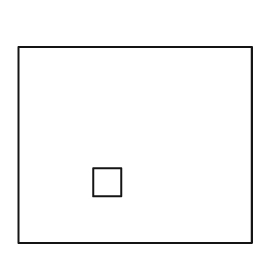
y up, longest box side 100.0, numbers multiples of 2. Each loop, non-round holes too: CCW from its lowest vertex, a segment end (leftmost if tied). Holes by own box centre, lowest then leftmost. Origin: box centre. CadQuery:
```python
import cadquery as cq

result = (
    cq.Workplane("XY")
    .moveTo(-50.0, -42.0)
    .lineTo(50.0, -42.0)
    .lineTo(50.0, 42.0)
    .lineTo(-50.0, 42.0)
    .close()
    .moveTo(-18.0, -22.0)
    .lineTo(-6.0, -22.0)
    .lineTo(-6.0, -10.0)
    .lineTo(-18.0, -10.0)
    .close()
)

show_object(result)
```